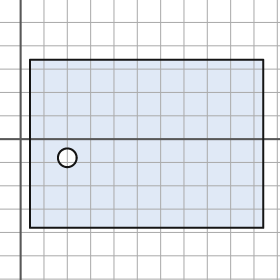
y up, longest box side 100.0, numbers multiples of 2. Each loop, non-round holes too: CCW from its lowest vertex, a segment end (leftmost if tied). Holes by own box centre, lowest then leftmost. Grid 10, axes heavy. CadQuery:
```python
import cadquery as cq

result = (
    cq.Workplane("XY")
    .moveTo(4.0, -38.0)
    .lineTo(104.0, -38.0)
    .lineTo(104.0, 34.0)
    .lineTo(4.0, 34.0)
    .close()
    .moveTo(20.0, -8.0)
    .circle(4.0)
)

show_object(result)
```